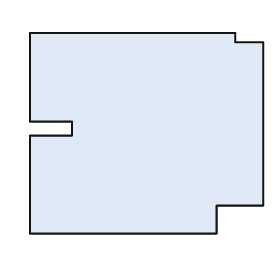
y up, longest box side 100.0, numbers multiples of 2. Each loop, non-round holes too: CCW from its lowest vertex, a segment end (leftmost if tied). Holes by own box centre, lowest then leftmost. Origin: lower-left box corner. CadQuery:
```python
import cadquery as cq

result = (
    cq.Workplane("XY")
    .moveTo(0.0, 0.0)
    .lineTo(80.0, 0.0)
    .lineTo(80.0, 12.0)
    .lineTo(100.0, 12.0)
    .lineTo(100.0, 82.0)
    .lineTo(88.0, 82.0)
    .lineTo(88.0, 86.0)
    .lineTo(0.0, 86.0)
    .lineTo(0.0, 48.0)
    .lineTo(18.0, 48.0)
    .lineTo(18.0, 42.0)
    .lineTo(0.0, 42.0)
    .close()
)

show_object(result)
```